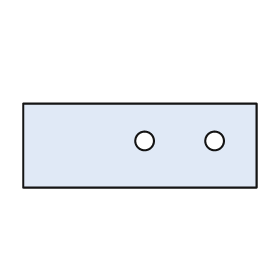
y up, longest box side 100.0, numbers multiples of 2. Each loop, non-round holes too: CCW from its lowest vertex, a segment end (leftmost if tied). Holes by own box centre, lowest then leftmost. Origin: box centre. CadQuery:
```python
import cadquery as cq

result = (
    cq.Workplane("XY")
    .moveTo(-50.0, -18.0)
    .lineTo(50.0, -18.0)
    .lineTo(50.0, 18.0)
    .lineTo(-50.0, 18.0)
    .close()
    .moveTo(2.0, 2.0)
    .circle(4.0)
    .moveTo(32.0, 2.0)
    .circle(4.0)
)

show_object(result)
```